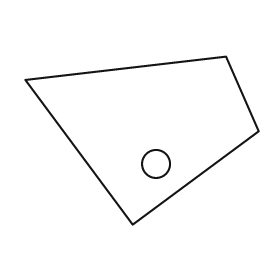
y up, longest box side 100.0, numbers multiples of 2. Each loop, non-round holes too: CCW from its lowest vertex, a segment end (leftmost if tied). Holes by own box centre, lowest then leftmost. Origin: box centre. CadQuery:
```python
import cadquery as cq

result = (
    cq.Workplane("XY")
    .moveTo(-4.0, -36.0)
    .lineTo(50.0, 4.0)
    .lineTo(36.0, 36.0)
    .lineTo(-50.0, 26.0)
    .close()
    .moveTo(6.0, -10.0)
    .circle(6.0)
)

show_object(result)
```